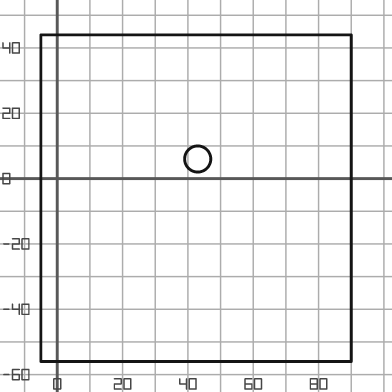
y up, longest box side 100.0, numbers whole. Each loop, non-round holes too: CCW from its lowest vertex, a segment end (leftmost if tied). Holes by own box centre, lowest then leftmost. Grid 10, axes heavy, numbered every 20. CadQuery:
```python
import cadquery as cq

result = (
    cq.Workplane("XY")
    .moveTo(-5.0, -56.0)
    .lineTo(90.0, -56.0)
    .lineTo(90.0, 44.0)
    .lineTo(-5.0, 44.0)
    .close()
    .moveTo(43.0, 6.0)
    .circle(4.0)
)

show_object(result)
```